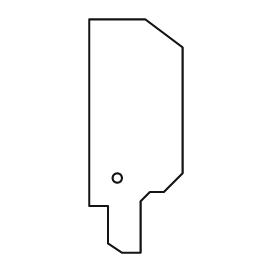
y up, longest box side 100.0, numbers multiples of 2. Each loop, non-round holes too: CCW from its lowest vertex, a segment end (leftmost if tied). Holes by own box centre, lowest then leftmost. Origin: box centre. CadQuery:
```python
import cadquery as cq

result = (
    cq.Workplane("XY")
    .moveTo(-6.0, -50.0)
    .lineTo(2.0, -50.0)
    .lineTo(2.0, -28.0)
    .lineTo(6.0, -24.0)
    .lineTo(12.0, -24.0)
    .lineTo(20.0, -16.0)
    .lineTo(20.0, 38.0)
    .lineTo(4.0, 50.0)
    .lineTo(-20.0, 50.0)
    .lineTo(-20.0, -30.0)
    .lineTo(-12.0, -30.0)
    .lineTo(-12.0, -46.0)
    .close()
    .moveTo(-8.0, -18.0)
    .circle(2.0)
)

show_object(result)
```